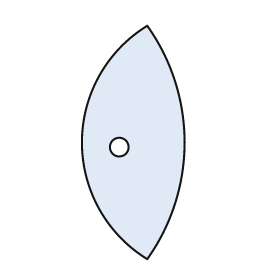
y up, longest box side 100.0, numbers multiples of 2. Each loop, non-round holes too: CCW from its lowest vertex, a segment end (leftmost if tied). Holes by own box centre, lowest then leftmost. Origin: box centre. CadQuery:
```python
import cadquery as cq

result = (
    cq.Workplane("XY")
    .moveTo(6.0, -50.0)
    .threePointArc((22.0, 0.0), (6.0, 50.0))
    .threePointArc((-22.0, 0.0), (6.0, -50.0))
    .close()
    .moveTo(-6.0, -2.0)
    .circle(4.0)
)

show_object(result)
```